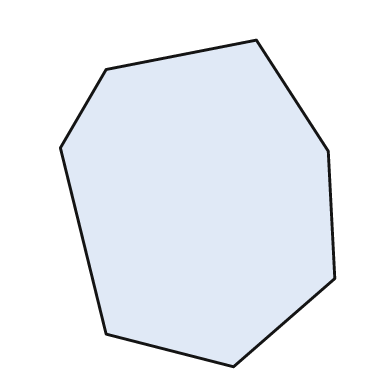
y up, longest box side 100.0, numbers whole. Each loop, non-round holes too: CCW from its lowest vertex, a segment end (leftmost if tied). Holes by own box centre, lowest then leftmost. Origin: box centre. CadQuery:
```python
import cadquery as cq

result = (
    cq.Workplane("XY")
    .moveTo(11.0, -50.0)
    .lineTo(42.0, -23.0)
    .lineTo(40.0, 16.0)
    .lineTo(18.0, 50.0)
    .lineTo(-28.0, 41.0)
    .lineTo(-42.0, 17.0)
    .lineTo(-28.0, -40.0)
    .close()
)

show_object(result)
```